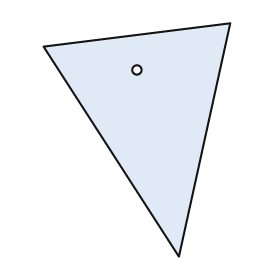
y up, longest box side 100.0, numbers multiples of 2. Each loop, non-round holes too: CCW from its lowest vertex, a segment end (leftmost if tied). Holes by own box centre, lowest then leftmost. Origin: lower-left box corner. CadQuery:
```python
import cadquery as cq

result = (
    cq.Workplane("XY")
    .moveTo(58.0, 0.0)
    .lineTo(80.0, 100.0)
    .lineTo(0.0, 90.0)
    .close()
    .moveTo(40.0, 80.0)
    .circle(2.0)
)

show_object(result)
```